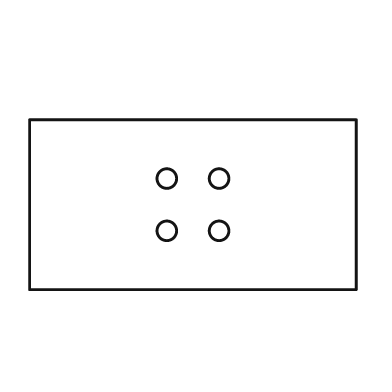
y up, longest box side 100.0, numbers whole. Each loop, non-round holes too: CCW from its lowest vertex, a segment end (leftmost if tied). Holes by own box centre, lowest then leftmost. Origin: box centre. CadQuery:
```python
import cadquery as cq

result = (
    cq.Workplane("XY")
    .moveTo(-50.0, -26.0)
    .lineTo(50.0, -26.0)
    .lineTo(50.0, 26.0)
    .lineTo(-50.0, 26.0)
    .close()
    .moveTo(-8.0, -8.0)
    .circle(3.0)
    .moveTo(8.0, -8.0)
    .circle(3.0)
    .moveTo(-8.0, 8.0)
    .circle(3.0)
    .moveTo(8.0, 8.0)
    .circle(3.0)
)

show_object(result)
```